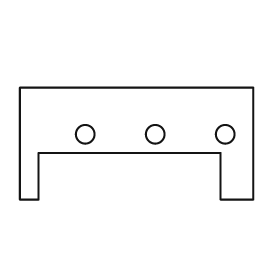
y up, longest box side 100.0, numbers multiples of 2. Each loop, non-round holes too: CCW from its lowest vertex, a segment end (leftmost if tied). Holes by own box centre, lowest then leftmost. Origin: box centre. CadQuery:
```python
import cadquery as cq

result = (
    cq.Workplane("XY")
    .moveTo(-50.0, -24.0)
    .lineTo(-42.0, -24.0)
    .lineTo(-42.0, -4.0)
    .lineTo(36.0, -4.0)
    .lineTo(36.0, -24.0)
    .lineTo(50.0, -24.0)
    .lineTo(50.0, 24.0)
    .lineTo(-50.0, 24.0)
    .close()
    .moveTo(-22.0, 4.0)
    .circle(4.0)
    .moveTo(8.0, 4.0)
    .circle(4.0)
    .moveTo(38.0, 4.0)
    .circle(4.0)
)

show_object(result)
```